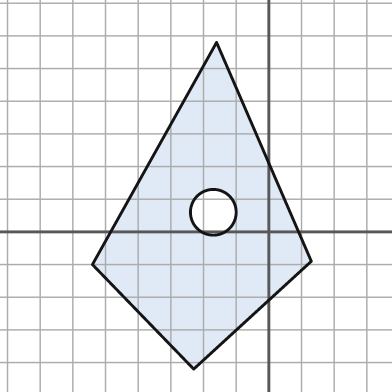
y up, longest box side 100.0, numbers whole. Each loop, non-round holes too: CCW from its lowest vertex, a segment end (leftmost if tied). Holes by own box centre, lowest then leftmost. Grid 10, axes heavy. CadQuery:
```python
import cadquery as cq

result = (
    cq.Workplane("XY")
    .moveTo(-23.0, -42.0)
    .lineTo(13.0, -9.0)
    .lineTo(-16.0, 58.0)
    .lineTo(-54.0, -10.0)
    .close()
    .moveTo(-17.0, 6.0)
    .circle(7.0)
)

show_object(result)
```